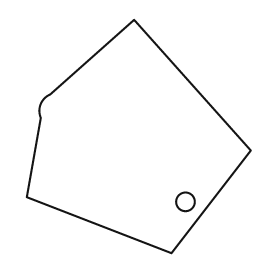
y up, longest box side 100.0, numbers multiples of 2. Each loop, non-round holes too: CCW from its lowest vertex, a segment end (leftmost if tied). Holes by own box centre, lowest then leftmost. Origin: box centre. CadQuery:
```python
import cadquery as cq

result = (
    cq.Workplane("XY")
    .moveTo(14.0, -50.0)
    .lineTo(48.0, -6.0)
    .lineTo(-2.0, 50.0)
    .lineTo(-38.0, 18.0)
    .threePointArc((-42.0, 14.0), (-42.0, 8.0))
    .lineTo(-48.0, -26.0)
    .close()
    .moveTo(20.0, -28.0)
    .circle(4.0)
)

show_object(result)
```